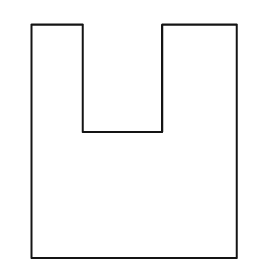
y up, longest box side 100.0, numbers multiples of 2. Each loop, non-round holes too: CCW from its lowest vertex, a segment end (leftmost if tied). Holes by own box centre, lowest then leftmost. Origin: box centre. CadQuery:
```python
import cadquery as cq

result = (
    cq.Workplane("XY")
    .moveTo(-44.0, -50.0)
    .lineTo(44.0, -50.0)
    .lineTo(44.0, 50.0)
    .lineTo(12.0, 50.0)
    .lineTo(12.0, 4.0)
    .lineTo(-22.0, 4.0)
    .lineTo(-22.0, 50.0)
    .lineTo(-44.0, 50.0)
    .close()
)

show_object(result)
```